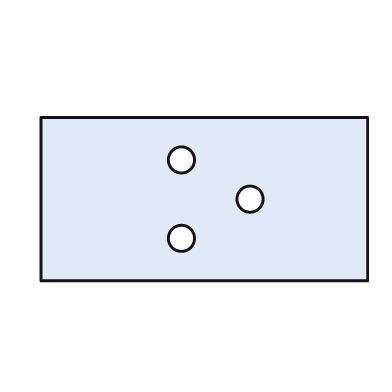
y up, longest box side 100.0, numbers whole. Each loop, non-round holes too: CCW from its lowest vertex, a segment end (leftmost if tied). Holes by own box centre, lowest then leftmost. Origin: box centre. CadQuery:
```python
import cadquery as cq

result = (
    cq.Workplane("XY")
    .moveTo(-50.0, -25.0)
    .lineTo(50.0, -25.0)
    .lineTo(50.0, 25.0)
    .lineTo(-50.0, 25.0)
    .close()
    .moveTo(-7.0, -12.0)
    .circle(4.0)
    .moveTo(14.0, 0.0)
    .circle(4.0)
    .moveTo(-7.0, 12.0)
    .circle(4.0)
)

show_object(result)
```